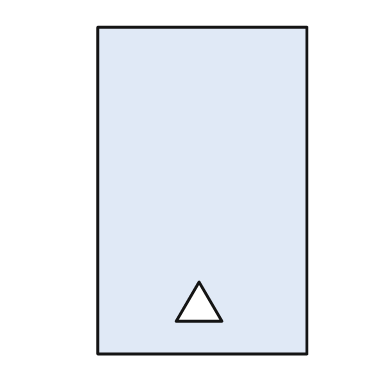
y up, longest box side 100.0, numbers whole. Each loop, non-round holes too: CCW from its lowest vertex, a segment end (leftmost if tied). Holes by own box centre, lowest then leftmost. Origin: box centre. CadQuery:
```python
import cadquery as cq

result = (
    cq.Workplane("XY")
    .moveTo(-32.0, -50.0)
    .lineTo(32.0, -50.0)
    .lineTo(32.0, 50.0)
    .lineTo(-32.0, 50.0)
    .close()
    .moveTo(-8.0, -40.0)
    .lineTo(6.0, -40.0)
    .lineTo(-1.0, -28.0)
    .close()
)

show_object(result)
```